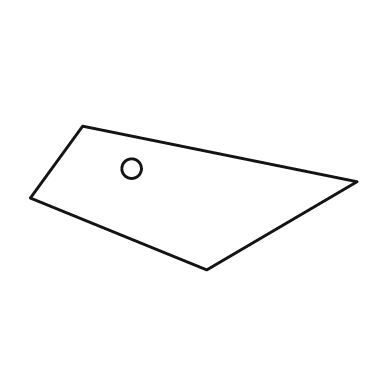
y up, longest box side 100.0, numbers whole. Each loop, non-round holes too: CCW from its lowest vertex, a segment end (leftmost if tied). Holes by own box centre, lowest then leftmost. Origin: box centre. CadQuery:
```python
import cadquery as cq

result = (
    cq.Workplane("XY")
    .moveTo(4.0, -22.0)
    .lineTo(50.0, 5.0)
    .lineTo(-34.0, 22.0)
    .lineTo(-50.0, 0.0)
    .close()
    .moveTo(-19.0, 9.0)
    .circle(3.0)
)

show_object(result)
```